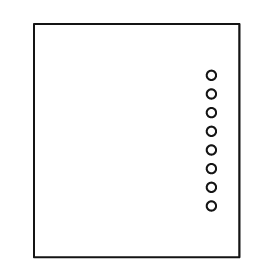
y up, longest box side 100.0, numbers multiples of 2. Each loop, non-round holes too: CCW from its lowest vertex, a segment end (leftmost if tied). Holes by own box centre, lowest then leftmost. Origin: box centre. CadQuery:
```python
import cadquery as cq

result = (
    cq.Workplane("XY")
    .moveTo(-44.0, -50.0)
    .lineTo(44.0, -50.0)
    .lineTo(44.0, 50.0)
    .lineTo(-44.0, 50.0)
    .close()
    .moveTo(32.0, -28.0)
    .circle(2.0)
    .moveTo(32.0, -20.0)
    .circle(2.0)
    .moveTo(32.0, -12.0)
    .circle(2.0)
    .moveTo(32.0, -4.0)
    .circle(2.0)
    .moveTo(32.0, 4.0)
    .circle(2.0)
    .moveTo(32.0, 12.0)
    .circle(2.0)
    .moveTo(32.0, 20.0)
    .circle(2.0)
    .moveTo(32.0, 28.0)
    .circle(2.0)
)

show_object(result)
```